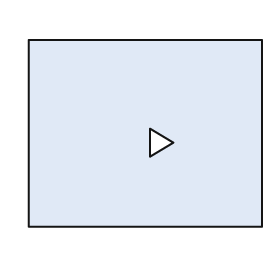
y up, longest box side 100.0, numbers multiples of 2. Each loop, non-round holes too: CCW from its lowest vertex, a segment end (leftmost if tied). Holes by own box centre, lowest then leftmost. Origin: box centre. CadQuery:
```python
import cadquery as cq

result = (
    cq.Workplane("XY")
    .moveTo(-50.0, -40.0)
    .lineTo(50.0, -40.0)
    .lineTo(50.0, 40.0)
    .lineTo(-50.0, 40.0)
    .close()
    .moveTo(2.0, -10.0)
    .lineTo(12.0, -4.0)
    .lineTo(2.0, 2.0)
    .close()
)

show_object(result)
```